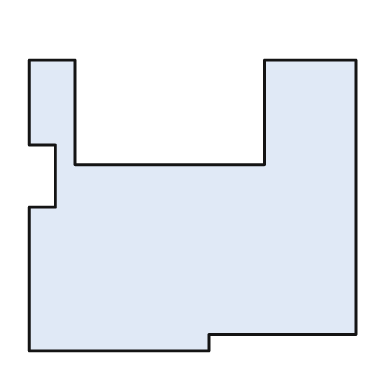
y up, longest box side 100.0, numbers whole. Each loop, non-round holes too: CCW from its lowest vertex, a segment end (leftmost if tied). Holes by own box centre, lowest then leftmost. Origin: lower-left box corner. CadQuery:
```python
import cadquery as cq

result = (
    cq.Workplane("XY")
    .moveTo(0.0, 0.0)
    .lineTo(55.0, 0.0)
    .lineTo(55.0, 5.0)
    .lineTo(100.0, 5.0)
    .lineTo(100.0, 89.0)
    .lineTo(72.0, 89.0)
    .lineTo(72.0, 57.0)
    .lineTo(14.0, 57.0)
    .lineTo(14.0, 89.0)
    .lineTo(0.0, 89.0)
    .lineTo(0.0, 63.0)
    .lineTo(8.0, 63.0)
    .lineTo(8.0, 44.0)
    .lineTo(0.0, 44.0)
    .close()
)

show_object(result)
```